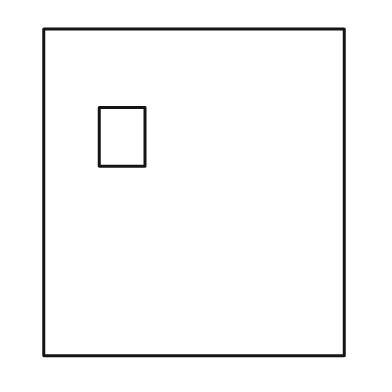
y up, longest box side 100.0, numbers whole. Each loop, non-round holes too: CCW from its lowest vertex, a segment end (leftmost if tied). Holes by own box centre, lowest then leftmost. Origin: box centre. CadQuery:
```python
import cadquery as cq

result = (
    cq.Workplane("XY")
    .moveTo(-46.0, -50.0)
    .lineTo(46.0, -50.0)
    .lineTo(46.0, 50.0)
    .lineTo(-46.0, 50.0)
    .close()
    .moveTo(-29.0, 8.0)
    .lineTo(-15.0, 8.0)
    .lineTo(-15.0, 26.0)
    .lineTo(-29.0, 26.0)
    .close()
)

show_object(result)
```